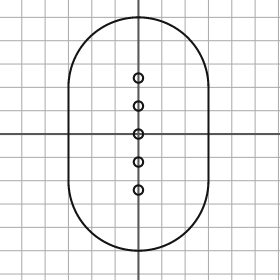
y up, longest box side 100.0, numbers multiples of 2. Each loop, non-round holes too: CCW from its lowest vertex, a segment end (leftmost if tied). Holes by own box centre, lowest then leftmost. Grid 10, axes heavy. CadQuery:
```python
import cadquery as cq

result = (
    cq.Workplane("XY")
    .moveTo(-30.0, -20.0)
    .threePointArc((0.0, -50.0), (30.0, -20.0))
    .lineTo(30.0, 20.0)
    .threePointArc((0.0, 50.0), (-30.0, 20.0))
    .close()
    .moveTo(0.0, -24.0)
    .circle(2.0)
    .moveTo(0.0, -12.0)
    .circle(2.0)
    .moveTo(0.0, 0.0)
    .circle(2.0)
    .moveTo(0.0, 12.0)
    .circle(2.0)
    .moveTo(0.0, 24.0)
    .circle(2.0)
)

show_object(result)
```